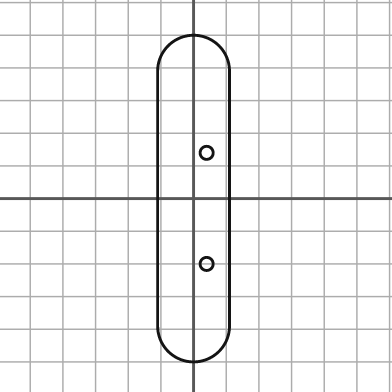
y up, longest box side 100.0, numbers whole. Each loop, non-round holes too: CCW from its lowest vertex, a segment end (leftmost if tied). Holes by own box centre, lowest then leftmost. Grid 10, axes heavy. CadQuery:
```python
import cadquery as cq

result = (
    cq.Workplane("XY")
    .moveTo(-11.0, -39.0)
    .threePointArc((0.0, -50.0), (11.0, -39.0))
    .lineTo(11.0, 39.0)
    .threePointArc((0.0, 50.0), (-11.0, 39.0))
    .close()
    .moveTo(4.0, -20.0)
    .circle(2.0)
    .moveTo(4.0, 14.0)
    .circle(2.0)
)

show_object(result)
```